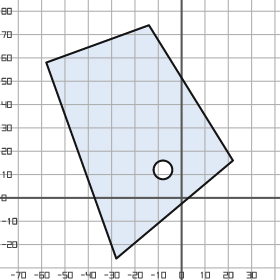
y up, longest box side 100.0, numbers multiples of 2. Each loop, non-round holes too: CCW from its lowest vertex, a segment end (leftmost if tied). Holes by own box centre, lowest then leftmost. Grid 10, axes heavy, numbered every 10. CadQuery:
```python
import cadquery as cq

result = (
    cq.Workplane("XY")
    .moveTo(-28.0, -26.0)
    .lineTo(22.0, 16.0)
    .lineTo(-14.0, 74.0)
    .lineTo(-58.0, 58.0)
    .close()
    .moveTo(-8.0, 12.0)
    .circle(4.0)
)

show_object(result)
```